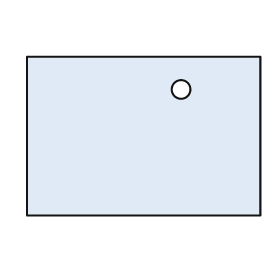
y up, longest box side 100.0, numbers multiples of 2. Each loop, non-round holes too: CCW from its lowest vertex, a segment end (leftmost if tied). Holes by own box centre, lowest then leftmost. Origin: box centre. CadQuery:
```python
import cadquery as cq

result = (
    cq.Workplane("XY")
    .moveTo(-50.0, -34.0)
    .lineTo(50.0, -34.0)
    .lineTo(50.0, 34.0)
    .lineTo(-50.0, 34.0)
    .close()
    .moveTo(16.0, 20.0)
    .circle(4.0)
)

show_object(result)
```